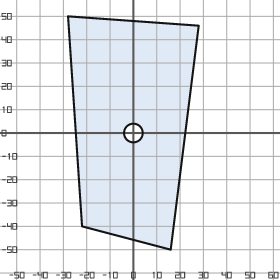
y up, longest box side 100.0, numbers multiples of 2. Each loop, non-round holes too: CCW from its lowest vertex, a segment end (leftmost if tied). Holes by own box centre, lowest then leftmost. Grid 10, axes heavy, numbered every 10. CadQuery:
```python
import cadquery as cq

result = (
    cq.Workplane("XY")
    .moveTo(16.0, -50.0)
    .lineTo(28.0, 46.0)
    .lineTo(-28.0, 50.0)
    .lineTo(-22.0, -40.0)
    .close()
    .moveTo(0.0, 0.0)
    .circle(4.0)
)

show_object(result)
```